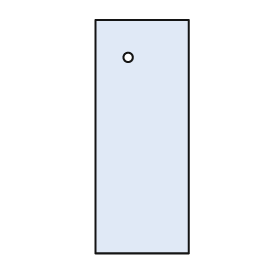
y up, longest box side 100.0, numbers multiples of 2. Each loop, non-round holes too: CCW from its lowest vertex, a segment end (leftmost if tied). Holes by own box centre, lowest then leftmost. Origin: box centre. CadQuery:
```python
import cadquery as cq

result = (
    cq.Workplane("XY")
    .moveTo(-20.0, -50.0)
    .lineTo(20.0, -50.0)
    .lineTo(20.0, 50.0)
    .lineTo(-20.0, 50.0)
    .close()
    .moveTo(-6.0, 34.0)
    .circle(2.0)
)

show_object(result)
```